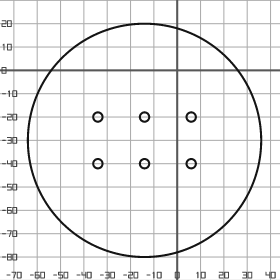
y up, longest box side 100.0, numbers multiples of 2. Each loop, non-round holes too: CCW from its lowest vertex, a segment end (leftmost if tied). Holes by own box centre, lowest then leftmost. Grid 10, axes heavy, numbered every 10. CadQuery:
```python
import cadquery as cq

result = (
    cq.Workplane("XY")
    .moveTo(-14.0, -30.0)
    .circle(50.0)
    .moveTo(-34.0, -40.0)
    .circle(2.0)
    .moveTo(-14.0, -40.0)
    .circle(2.0)
    .moveTo(6.0, -40.0)
    .circle(2.0)
    .moveTo(-34.0, -20.0)
    .circle(2.0)
    .moveTo(-14.0, -20.0)
    .circle(2.0)
    .moveTo(6.0, -20.0)
    .circle(2.0)
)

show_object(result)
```